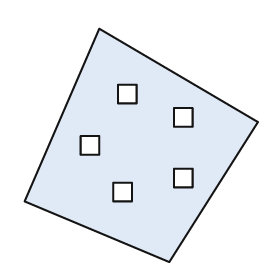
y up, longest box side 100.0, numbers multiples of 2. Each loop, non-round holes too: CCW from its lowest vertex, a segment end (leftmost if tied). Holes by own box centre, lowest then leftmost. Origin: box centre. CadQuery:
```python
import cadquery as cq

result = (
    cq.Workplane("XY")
    .moveTo(12.0, -50.0)
    .lineTo(50.0, 10.0)
    .lineTo(-18.0, 50.0)
    .lineTo(-50.0, -24.0)
    .close()
    .moveTo(-12.0, -24.0)
    .lineTo(-4.0, -24.0)
    .lineTo(-4.0, -16.0)
    .lineTo(-12.0, -16.0)
    .close()
    .moveTo(14.0, -18.0)
    .lineTo(22.0, -18.0)
    .lineTo(22.0, -10.0)
    .lineTo(14.0, -10.0)
    .close()
    .moveTo(-26.0, -4.0)
    .lineTo(-18.0, -4.0)
    .lineTo(-18.0, 4.0)
    .lineTo(-26.0, 4.0)
    .close()
    .moveTo(14.0, 8.0)
    .lineTo(22.0, 8.0)
    .lineTo(22.0, 16.0)
    .lineTo(14.0, 16.0)
    .close()
    .moveTo(-10.0, 18.0)
    .lineTo(-2.0, 18.0)
    .lineTo(-2.0, 26.0)
    .lineTo(-10.0, 26.0)
    .close()
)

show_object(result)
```